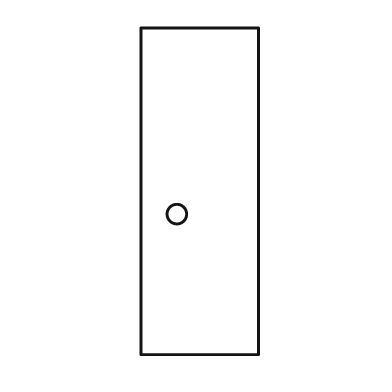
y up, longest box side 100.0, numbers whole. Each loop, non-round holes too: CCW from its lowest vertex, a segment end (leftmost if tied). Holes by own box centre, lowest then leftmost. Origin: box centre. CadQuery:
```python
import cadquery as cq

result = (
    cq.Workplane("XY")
    .moveTo(-18.0, -50.0)
    .lineTo(18.0, -50.0)
    .lineTo(18.0, 50.0)
    .lineTo(-18.0, 50.0)
    .close()
    .moveTo(-7.0, -7.0)
    .circle(3.0)
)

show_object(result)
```